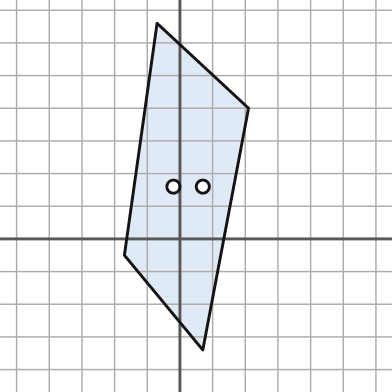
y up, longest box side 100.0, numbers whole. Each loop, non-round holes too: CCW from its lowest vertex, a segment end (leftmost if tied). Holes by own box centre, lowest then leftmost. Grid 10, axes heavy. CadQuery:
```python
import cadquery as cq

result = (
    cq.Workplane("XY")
    .moveTo(7.0, -34.0)
    .lineTo(21.0, 40.0)
    .lineTo(-7.0, 66.0)
    .lineTo(-17.0, -5.0)
    .close()
    .moveTo(-2.0, 16.0)
    .circle(2.0)
    .moveTo(7.0, 16.0)
    .circle(2.0)
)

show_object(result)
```